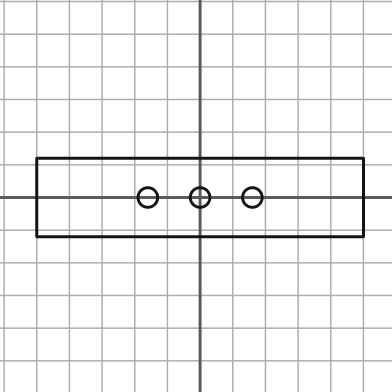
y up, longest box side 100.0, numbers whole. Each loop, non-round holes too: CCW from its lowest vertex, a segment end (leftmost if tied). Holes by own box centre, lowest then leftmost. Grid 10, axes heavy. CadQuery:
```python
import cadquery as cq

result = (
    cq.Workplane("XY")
    .moveTo(-50.0, -12.0)
    .lineTo(50.0, -12.0)
    .lineTo(50.0, 12.0)
    .lineTo(-50.0, 12.0)
    .close()
    .moveTo(-16.0, 0.0)
    .circle(3.0)
    .moveTo(0.0, 0.0)
    .circle(3.0)
    .moveTo(16.0, 0.0)
    .circle(3.0)
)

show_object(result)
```